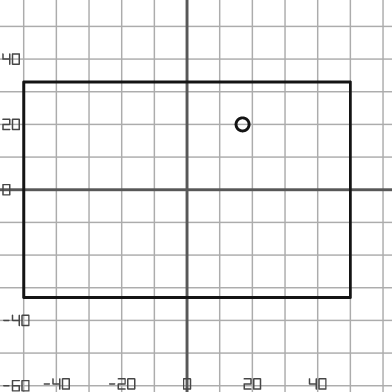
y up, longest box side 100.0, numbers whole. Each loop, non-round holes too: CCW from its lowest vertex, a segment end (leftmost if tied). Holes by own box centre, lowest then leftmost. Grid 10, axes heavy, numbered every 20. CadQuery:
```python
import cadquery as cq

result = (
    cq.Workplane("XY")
    .moveTo(-50.0, -33.0)
    .lineTo(50.0, -33.0)
    .lineTo(50.0, 33.0)
    .lineTo(-50.0, 33.0)
    .close()
    .moveTo(17.0, 20.0)
    .circle(2.0)
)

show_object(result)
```